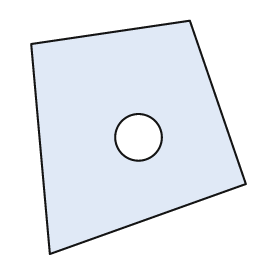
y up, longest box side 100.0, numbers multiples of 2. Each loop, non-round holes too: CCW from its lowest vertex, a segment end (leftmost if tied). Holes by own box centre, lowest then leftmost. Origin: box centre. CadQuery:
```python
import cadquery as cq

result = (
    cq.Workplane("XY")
    .moveTo(-38.0, -50.0)
    .lineTo(46.0, -20.0)
    .lineTo(22.0, 50.0)
    .lineTo(-46.0, 40.0)
    .close()
    .moveTo(0.0, 0.0)
    .circle(10.0)
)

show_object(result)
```